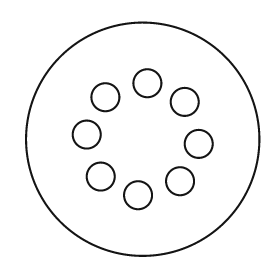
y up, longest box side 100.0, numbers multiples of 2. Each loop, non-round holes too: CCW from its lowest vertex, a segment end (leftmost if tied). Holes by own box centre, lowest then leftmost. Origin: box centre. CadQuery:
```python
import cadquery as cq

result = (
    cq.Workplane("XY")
    .moveTo(0.0, 0.0)
    .circle(50.0)
    .moveTo(-2.0, -24.0)
    .circle(6.0)
    .moveTo(16.0, -18.0)
    .circle(6.0)
    .moveTo(-18.0, -16.0)
    .circle(6.0)
    .moveTo(24.0, -2.0)
    .circle(6.0)
    .moveTo(-24.0, 2.0)
    .circle(6.0)
    .moveTo(18.0, 16.0)
    .circle(6.0)
    .moveTo(-16.0, 18.0)
    .circle(6.0)
    .moveTo(2.0, 24.0)
    .circle(6.0)
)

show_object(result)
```